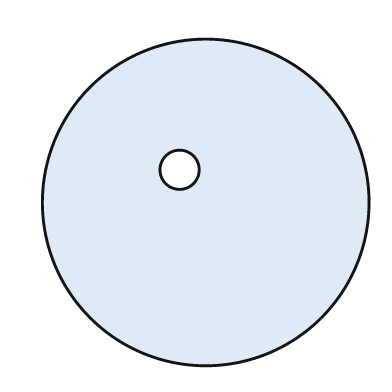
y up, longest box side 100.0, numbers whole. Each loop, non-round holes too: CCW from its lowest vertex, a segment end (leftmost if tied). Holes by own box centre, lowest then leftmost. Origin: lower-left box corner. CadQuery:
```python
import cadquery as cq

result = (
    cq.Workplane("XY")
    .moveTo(50.0, 50.0)
    .circle(50.0)
    .moveTo(42.0, 60.0)
    .circle(6.0)
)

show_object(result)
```